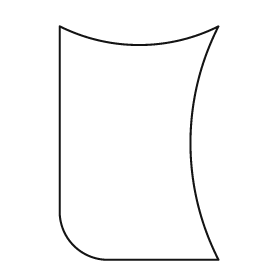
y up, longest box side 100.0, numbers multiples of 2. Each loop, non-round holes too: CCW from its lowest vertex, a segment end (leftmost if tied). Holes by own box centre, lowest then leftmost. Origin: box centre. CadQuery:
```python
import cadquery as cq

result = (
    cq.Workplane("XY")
    .moveTo(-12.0, -50.0)
    .lineTo(34.0, -50.0)
    .threePointArc((22.0, 0.0), (34.0, 50.0))
    .threePointArc((0.0, 42.0), (-34.0, 50.0))
    .lineTo(-34.0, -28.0)
    .threePointArc((-28.0, -44.0), (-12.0, -50.0))
    .close()
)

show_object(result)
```